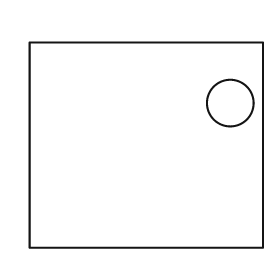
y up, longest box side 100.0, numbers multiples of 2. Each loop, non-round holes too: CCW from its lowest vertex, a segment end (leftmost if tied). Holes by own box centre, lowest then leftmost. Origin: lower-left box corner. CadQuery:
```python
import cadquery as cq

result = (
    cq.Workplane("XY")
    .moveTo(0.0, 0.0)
    .lineTo(100.0, 0.0)
    .lineTo(100.0, 88.0)
    .lineTo(0.0, 88.0)
    .close()
    .moveTo(86.0, 62.0)
    .circle(10.0)
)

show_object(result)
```